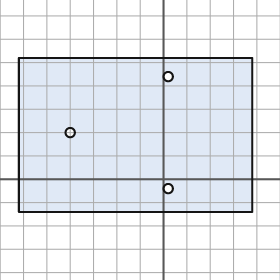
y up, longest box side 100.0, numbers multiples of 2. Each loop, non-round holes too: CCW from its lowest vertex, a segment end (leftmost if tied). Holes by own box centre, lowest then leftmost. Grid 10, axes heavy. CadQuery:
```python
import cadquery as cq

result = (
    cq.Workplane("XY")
    .moveTo(-62.0, -14.0)
    .lineTo(38.0, -14.0)
    .lineTo(38.0, 52.0)
    .lineTo(-62.0, 52.0)
    .close()
    .moveTo(2.0, -4.0)
    .circle(2.0)
    .moveTo(-40.0, 20.0)
    .circle(2.0)
    .moveTo(2.0, 44.0)
    .circle(2.0)
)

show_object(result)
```